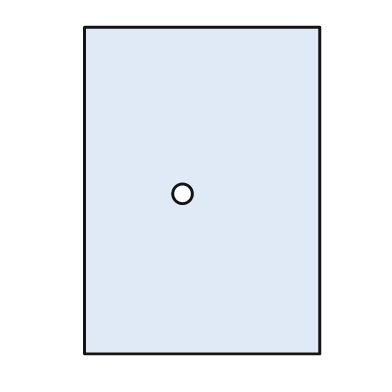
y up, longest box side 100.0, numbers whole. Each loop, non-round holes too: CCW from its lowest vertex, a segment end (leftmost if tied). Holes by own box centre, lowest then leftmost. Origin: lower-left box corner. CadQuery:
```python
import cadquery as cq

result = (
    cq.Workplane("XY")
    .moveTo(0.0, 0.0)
    .lineTo(72.0, 0.0)
    .lineTo(72.0, 100.0)
    .lineTo(0.0, 100.0)
    .close()
    .moveTo(30.0, 49.0)
    .circle(3.0)
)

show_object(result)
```